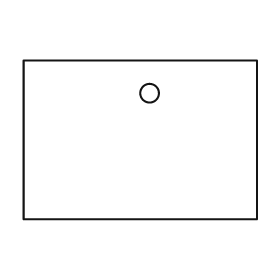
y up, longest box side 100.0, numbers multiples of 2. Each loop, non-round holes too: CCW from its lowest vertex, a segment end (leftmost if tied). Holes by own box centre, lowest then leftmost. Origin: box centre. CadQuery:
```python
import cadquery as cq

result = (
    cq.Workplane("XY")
    .moveTo(-50.0, -34.0)
    .lineTo(50.0, -34.0)
    .lineTo(50.0, 34.0)
    .lineTo(-50.0, 34.0)
    .close()
    .moveTo(4.0, 20.0)
    .circle(4.0)
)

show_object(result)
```